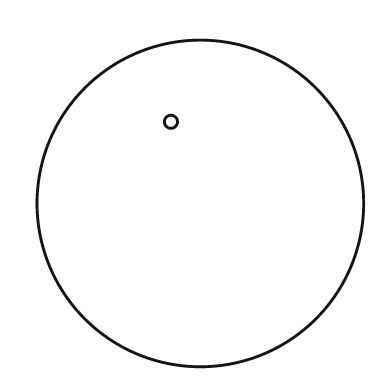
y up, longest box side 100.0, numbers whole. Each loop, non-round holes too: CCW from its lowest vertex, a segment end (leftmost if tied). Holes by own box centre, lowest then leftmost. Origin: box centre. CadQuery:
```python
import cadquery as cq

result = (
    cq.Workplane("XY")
    .moveTo(0.0, 0.0)
    .circle(50.0)
    .moveTo(-9.0, 25.0)
    .circle(2.0)
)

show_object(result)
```